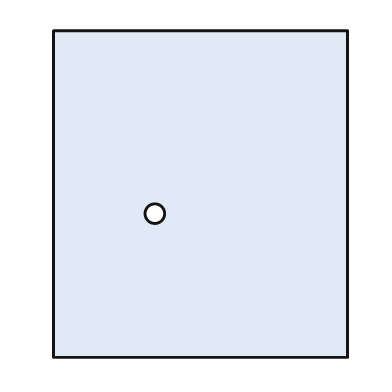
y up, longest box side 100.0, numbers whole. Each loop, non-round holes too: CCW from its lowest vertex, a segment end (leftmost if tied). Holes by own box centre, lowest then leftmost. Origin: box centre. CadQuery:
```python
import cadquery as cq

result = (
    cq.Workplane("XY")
    .moveTo(-45.0, -50.0)
    .lineTo(45.0, -50.0)
    .lineTo(45.0, 50.0)
    .lineTo(-45.0, 50.0)
    .close()
    .moveTo(-14.0, -6.0)
    .circle(3.0)
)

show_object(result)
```